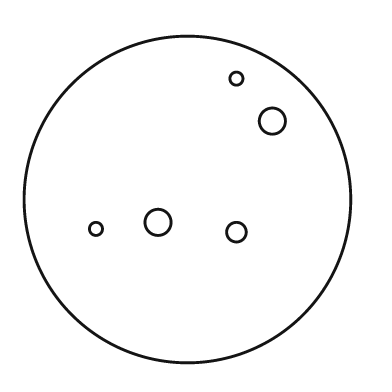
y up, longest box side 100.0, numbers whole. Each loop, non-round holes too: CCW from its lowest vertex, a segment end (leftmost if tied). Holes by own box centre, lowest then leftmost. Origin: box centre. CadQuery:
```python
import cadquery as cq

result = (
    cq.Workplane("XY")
    .moveTo(0.0, 0.0)
    .circle(50.0)
    .moveTo(15.0, -10.0)
    .circle(3.0)
    .moveTo(-28.0, -9.0)
    .circle(2.0)
    .moveTo(-9.0, -7.0)
    .circle(4.0)
    .moveTo(26.0, 24.0)
    .circle(4.0)
    .moveTo(15.0, 37.0)
    .circle(2.0)
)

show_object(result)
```